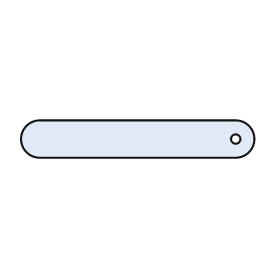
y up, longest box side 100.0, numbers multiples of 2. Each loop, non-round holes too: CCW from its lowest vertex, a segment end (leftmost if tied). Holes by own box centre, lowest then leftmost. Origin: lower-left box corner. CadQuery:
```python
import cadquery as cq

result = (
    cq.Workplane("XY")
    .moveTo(8.0, 0.0)
    .lineTo(92.0, 0.0)
    .threePointArc((100.0, 8.0), (92.0, 16.0))
    .lineTo(8.0, 16.0)
    .threePointArc((0.0, 8.0), (8.0, 0.0))
    .close()
    .moveTo(92.0, 8.0)
    .circle(2.0)
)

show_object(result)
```